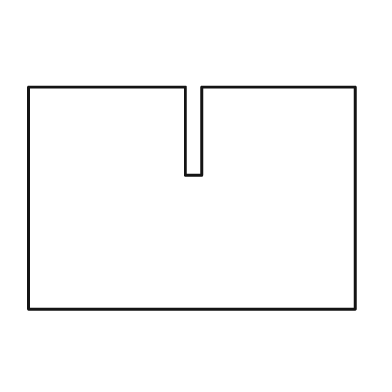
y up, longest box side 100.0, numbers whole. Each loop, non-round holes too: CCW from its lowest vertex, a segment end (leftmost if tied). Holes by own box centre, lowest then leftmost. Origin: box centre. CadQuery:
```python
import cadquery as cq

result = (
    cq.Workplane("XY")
    .moveTo(-50.0, -34.0)
    .lineTo(50.0, -34.0)
    .lineTo(50.0, 34.0)
    .lineTo(3.0, 34.0)
    .lineTo(3.0, 7.0)
    .lineTo(-2.0, 7.0)
    .lineTo(-2.0, 34.0)
    .lineTo(-50.0, 34.0)
    .close()
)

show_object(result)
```